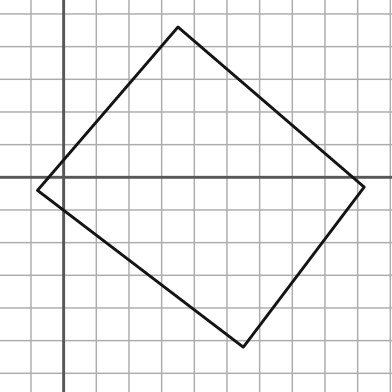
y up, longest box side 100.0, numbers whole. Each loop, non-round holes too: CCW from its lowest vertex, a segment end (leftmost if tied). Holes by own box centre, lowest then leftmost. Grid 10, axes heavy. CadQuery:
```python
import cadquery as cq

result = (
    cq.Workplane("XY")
    .moveTo(55.0, -52.0)
    .lineTo(92.0, -3.0)
    .lineTo(35.0, 46.0)
    .lineTo(-8.0, -4.0)
    .close()
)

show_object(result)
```